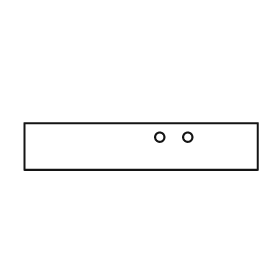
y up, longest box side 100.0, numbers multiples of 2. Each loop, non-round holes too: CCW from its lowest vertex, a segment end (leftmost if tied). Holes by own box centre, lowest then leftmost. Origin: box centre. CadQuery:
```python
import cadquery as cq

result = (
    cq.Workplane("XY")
    .moveTo(-50.0, -10.0)
    .lineTo(50.0, -10.0)
    .lineTo(50.0, 10.0)
    .lineTo(-50.0, 10.0)
    .close()
    .moveTo(8.0, 4.0)
    .circle(2.0)
    .moveTo(20.0, 4.0)
    .circle(2.0)
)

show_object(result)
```